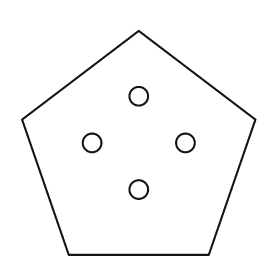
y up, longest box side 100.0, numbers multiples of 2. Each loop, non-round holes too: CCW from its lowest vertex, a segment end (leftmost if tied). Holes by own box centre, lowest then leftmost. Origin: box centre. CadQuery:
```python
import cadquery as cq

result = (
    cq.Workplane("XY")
    .moveTo(-30.0, -48.0)
    .lineTo(30.0, -48.0)
    .lineTo(50.0, 10.0)
    .lineTo(0.0, 48.0)
    .lineTo(-50.0, 10.0)
    .close()
    .moveTo(0.0, -20.0)
    .circle(4.0)
    .moveTo(-20.0, 0.0)
    .circle(4.0)
    .moveTo(20.0, 0.0)
    .circle(4.0)
    .moveTo(0.0, 20.0)
    .circle(4.0)
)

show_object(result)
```